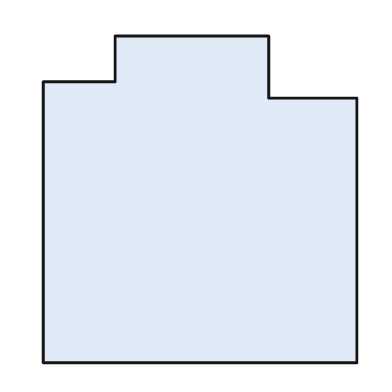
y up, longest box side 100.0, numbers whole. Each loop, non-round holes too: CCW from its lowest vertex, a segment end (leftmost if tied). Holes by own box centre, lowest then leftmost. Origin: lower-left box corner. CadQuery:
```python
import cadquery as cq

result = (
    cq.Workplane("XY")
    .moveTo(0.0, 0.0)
    .lineTo(96.0, 0.0)
    .lineTo(96.0, 81.0)
    .lineTo(69.0, 81.0)
    .lineTo(69.0, 100.0)
    .lineTo(22.0, 100.0)
    .lineTo(22.0, 86.0)
    .lineTo(0.0, 86.0)
    .close()
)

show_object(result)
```